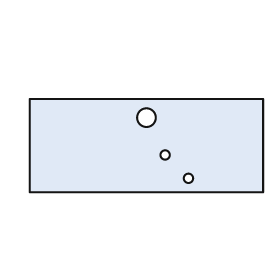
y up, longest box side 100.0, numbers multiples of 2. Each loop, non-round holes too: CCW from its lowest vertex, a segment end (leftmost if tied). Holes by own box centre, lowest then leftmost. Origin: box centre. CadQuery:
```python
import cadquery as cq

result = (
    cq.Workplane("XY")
    .moveTo(-50.0, -20.0)
    .lineTo(50.0, -20.0)
    .lineTo(50.0, 20.0)
    .lineTo(-50.0, 20.0)
    .close()
    .moveTo(18.0, -14.0)
    .circle(2.0)
    .moveTo(8.0, -4.0)
    .circle(2.0)
    .moveTo(0.0, 12.0)
    .circle(4.0)
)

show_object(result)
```